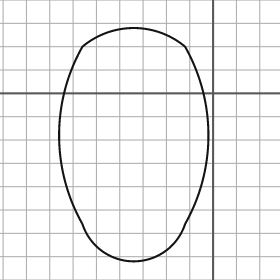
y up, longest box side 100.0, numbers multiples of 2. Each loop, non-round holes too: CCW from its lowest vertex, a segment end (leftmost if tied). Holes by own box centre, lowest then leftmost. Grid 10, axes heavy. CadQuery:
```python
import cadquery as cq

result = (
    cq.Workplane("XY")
    .moveTo(-56.0, -56.0)
    .threePointArc((-34.0, -72.0), (-12.0, -56.0))
    .threePointArc((-2.0, -18.0), (-12.0, 20.0))
    .threePointArc((-34.0, 28.0), (-56.0, 20.0))
    .threePointArc((-66.0, -18.0), (-56.0, -56.0))
    .close()
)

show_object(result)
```